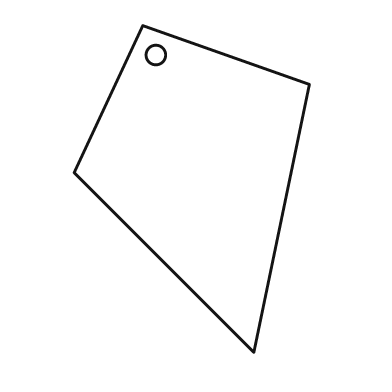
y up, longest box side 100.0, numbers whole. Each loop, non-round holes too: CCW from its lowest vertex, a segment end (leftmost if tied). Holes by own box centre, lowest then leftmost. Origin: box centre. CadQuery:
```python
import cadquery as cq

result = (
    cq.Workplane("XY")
    .moveTo(19.0, -50.0)
    .lineTo(36.0, 32.0)
    .lineTo(-15.0, 50.0)
    .lineTo(-36.0, 5.0)
    .close()
    .moveTo(-11.0, 41.0)
    .circle(3.0)
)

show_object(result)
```